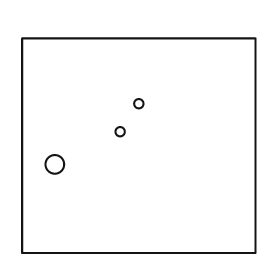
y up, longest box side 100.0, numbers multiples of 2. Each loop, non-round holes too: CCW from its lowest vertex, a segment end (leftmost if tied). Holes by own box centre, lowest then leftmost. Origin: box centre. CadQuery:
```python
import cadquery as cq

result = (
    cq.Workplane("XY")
    .moveTo(-50.0, -46.0)
    .lineTo(50.0, -46.0)
    .lineTo(50.0, 46.0)
    .lineTo(-50.0, 46.0)
    .close()
    .moveTo(-36.0, -8.0)
    .circle(4.0)
    .moveTo(-8.0, 6.0)
    .circle(2.0)
    .moveTo(0.0, 18.0)
    .circle(2.0)
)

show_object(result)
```